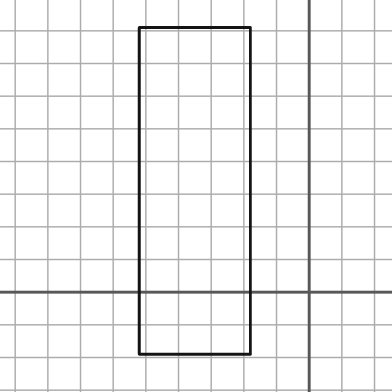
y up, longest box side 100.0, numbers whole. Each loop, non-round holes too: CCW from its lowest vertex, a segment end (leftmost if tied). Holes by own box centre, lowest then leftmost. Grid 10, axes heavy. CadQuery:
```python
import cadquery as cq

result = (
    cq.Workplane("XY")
    .moveTo(-52.0, -19.0)
    .lineTo(-18.0, -19.0)
    .lineTo(-18.0, 81.0)
    .lineTo(-52.0, 81.0)
    .close()
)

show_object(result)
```